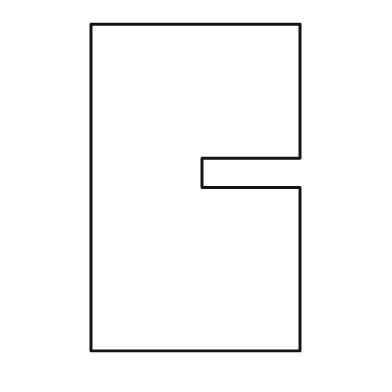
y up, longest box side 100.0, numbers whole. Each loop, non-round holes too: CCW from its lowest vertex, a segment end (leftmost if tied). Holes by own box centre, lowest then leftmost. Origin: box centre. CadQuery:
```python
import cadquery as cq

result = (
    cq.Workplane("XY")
    .moveTo(-32.0, -50.0)
    .lineTo(32.0, -50.0)
    .lineTo(32.0, 0.0)
    .lineTo(2.0, 0.0)
    .lineTo(2.0, 9.0)
    .lineTo(32.0, 9.0)
    .lineTo(32.0, 50.0)
    .lineTo(-32.0, 50.0)
    .close()
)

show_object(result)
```